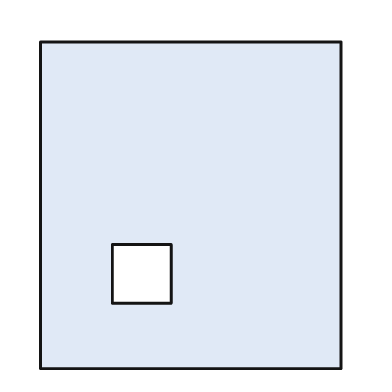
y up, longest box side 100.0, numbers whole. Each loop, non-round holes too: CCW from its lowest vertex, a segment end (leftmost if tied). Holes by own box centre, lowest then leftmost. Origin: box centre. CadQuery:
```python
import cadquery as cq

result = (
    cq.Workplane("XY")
    .moveTo(-46.0, -50.0)
    .lineTo(46.0, -50.0)
    .lineTo(46.0, 50.0)
    .lineTo(-46.0, 50.0)
    .close()
    .moveTo(-24.0, -30.0)
    .lineTo(-6.0, -30.0)
    .lineTo(-6.0, -12.0)
    .lineTo(-24.0, -12.0)
    .close()
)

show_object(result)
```